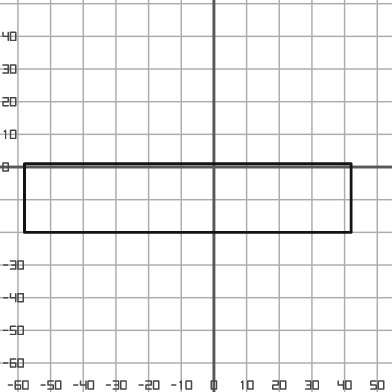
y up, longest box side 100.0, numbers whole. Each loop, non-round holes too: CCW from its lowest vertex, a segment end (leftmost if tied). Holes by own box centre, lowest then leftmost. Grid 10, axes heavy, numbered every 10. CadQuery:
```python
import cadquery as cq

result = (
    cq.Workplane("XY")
    .moveTo(-58.0, -20.0)
    .lineTo(42.0, -20.0)
    .lineTo(42.0, 1.0)
    .lineTo(-58.0, 1.0)
    .close()
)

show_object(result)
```